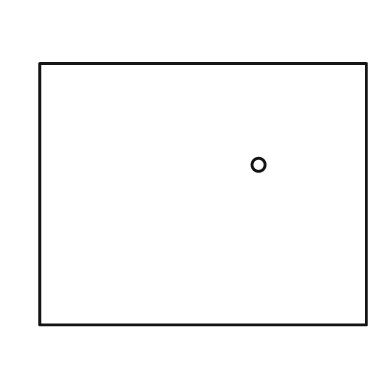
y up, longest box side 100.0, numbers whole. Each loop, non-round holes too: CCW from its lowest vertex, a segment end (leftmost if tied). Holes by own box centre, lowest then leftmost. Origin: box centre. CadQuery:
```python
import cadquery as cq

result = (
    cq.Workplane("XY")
    .moveTo(-50.0, -40.0)
    .lineTo(50.0, -40.0)
    .lineTo(50.0, 40.0)
    .lineTo(-50.0, 40.0)
    .close()
    .moveTo(17.0, 9.0)
    .circle(2.0)
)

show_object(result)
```